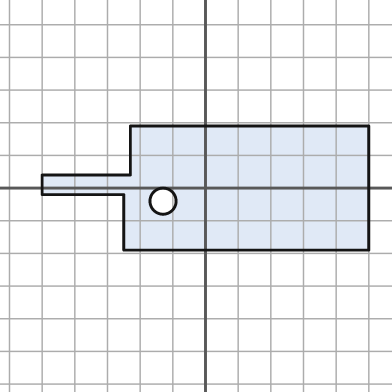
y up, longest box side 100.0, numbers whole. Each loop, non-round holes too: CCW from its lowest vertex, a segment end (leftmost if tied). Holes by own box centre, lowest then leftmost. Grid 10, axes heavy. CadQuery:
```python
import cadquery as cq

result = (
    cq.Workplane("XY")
    .moveTo(-25.0, -19.0)
    .lineTo(50.0, -19.0)
    .lineTo(50.0, 19.0)
    .lineTo(-23.0, 19.0)
    .lineTo(-23.0, 4.0)
    .lineTo(-50.0, 4.0)
    .lineTo(-50.0, -2.0)
    .lineTo(-25.0, -2.0)
    .close()
    .moveTo(-13.0, -4.0)
    .circle(4.0)
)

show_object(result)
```